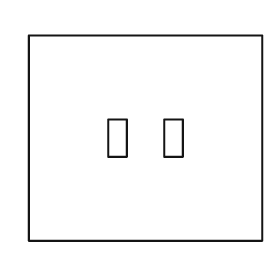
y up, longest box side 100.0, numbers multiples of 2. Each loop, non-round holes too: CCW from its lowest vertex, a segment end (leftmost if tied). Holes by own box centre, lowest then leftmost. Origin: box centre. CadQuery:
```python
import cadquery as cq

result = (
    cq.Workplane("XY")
    .moveTo(-50.0, -44.0)
    .lineTo(50.0, -44.0)
    .lineTo(50.0, 44.0)
    .lineTo(-50.0, 44.0)
    .close()
    .moveTo(-16.0, -8.0)
    .lineTo(-8.0, -8.0)
    .lineTo(-8.0, 8.0)
    .lineTo(-16.0, 8.0)
    .close()
    .moveTo(8.0, -8.0)
    .lineTo(16.0, -8.0)
    .lineTo(16.0, 8.0)
    .lineTo(8.0, 8.0)
    .close()
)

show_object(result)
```